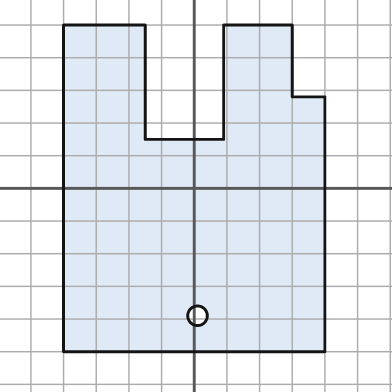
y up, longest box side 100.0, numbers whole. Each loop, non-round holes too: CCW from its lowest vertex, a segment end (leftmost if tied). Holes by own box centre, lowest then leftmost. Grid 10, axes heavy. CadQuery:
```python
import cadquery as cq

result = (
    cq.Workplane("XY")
    .moveTo(-40.0, -50.0)
    .lineTo(40.0, -50.0)
    .lineTo(40.0, 28.0)
    .lineTo(30.0, 28.0)
    .lineTo(30.0, 50.0)
    .lineTo(9.0, 50.0)
    .lineTo(9.0, 15.0)
    .lineTo(-15.0, 15.0)
    .lineTo(-15.0, 50.0)
    .lineTo(-40.0, 50.0)
    .close()
    .moveTo(1.0, -39.0)
    .circle(3.0)
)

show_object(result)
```